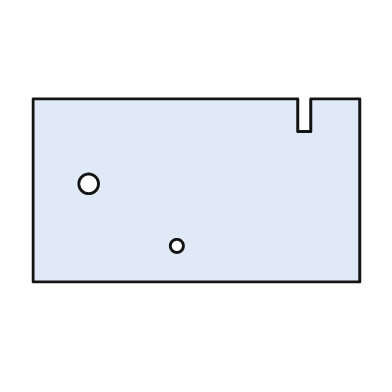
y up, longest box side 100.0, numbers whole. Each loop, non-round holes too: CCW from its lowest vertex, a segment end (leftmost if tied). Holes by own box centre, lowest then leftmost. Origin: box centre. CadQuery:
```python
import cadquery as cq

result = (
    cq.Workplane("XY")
    .moveTo(-50.0, -28.0)
    .lineTo(50.0, -28.0)
    .lineTo(50.0, 28.0)
    .lineTo(35.0, 28.0)
    .lineTo(35.0, 18.0)
    .lineTo(31.0, 18.0)
    .lineTo(31.0, 28.0)
    .lineTo(-50.0, 28.0)
    .close()
    .moveTo(-6.0, -17.0)
    .circle(2.0)
    .moveTo(-33.0, 2.0)
    .circle(3.0)
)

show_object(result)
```